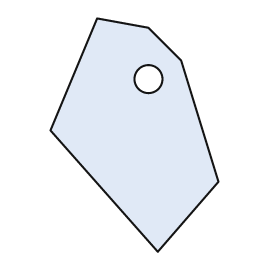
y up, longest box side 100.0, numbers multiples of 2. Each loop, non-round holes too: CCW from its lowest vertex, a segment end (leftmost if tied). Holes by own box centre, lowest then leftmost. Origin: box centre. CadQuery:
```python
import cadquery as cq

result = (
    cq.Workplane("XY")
    .moveTo(10.0, -50.0)
    .lineTo(36.0, -20.0)
    .lineTo(20.0, 32.0)
    .lineTo(6.0, 46.0)
    .lineTo(-16.0, 50.0)
    .lineTo(-36.0, 2.0)
    .close()
    .moveTo(6.0, 24.0)
    .circle(6.0)
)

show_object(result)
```